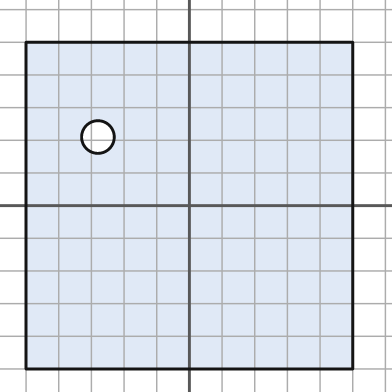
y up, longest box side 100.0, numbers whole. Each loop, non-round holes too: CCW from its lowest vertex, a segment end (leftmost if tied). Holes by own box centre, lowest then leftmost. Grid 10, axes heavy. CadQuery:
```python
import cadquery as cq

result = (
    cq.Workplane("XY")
    .moveTo(-50.0, -50.0)
    .lineTo(50.0, -50.0)
    .lineTo(50.0, 50.0)
    .lineTo(-50.0, 50.0)
    .close()
    .moveTo(-28.0, 21.0)
    .circle(5.0)
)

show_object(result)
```